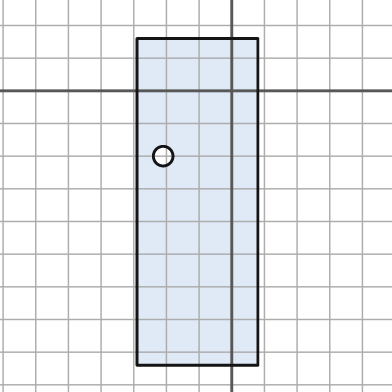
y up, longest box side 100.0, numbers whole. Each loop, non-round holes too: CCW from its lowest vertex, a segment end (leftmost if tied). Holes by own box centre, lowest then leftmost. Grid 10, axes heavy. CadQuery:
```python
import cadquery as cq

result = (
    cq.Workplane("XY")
    .moveTo(-29.0, -84.0)
    .lineTo(8.0, -84.0)
    .lineTo(8.0, 16.0)
    .lineTo(-29.0, 16.0)
    .close()
    .moveTo(-21.0, -20.0)
    .circle(3.0)
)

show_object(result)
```